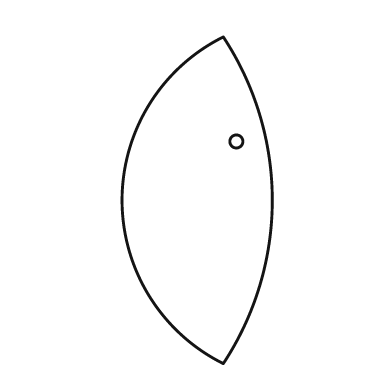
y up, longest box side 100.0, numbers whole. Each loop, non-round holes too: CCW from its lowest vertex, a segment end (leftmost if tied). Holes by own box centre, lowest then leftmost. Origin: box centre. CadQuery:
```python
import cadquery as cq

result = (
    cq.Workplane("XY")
    .moveTo(8.0, -50.0)
    .threePointArc((23.0, 0.0), (8.0, 50.0))
    .threePointArc((-23.0, 0.0), (8.0, -50.0))
    .close()
    .moveTo(12.0, 18.0)
    .circle(2.0)
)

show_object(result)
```